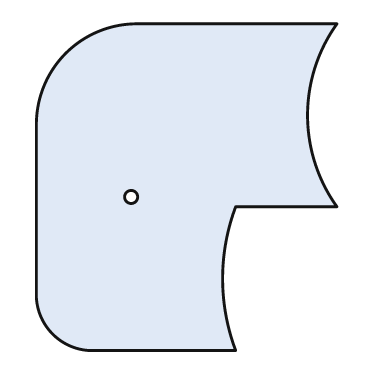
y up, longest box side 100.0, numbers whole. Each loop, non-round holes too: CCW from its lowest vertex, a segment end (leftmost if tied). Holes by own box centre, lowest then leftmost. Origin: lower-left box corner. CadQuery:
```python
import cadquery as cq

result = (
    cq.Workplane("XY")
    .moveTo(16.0, 0.0)
    .lineTo(61.0, 0.0)
    .threePointArc((57.0, 22.0), (61.0, 44.0))
    .lineTo(92.0, 44.0)
    .threePointArc((83.0, 72.0), (92.0, 100.0))
    .lineTo(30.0, 100.0)
    .threePointArc((9.0, 91.0), (0.0, 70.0))
    .lineTo(0.0, 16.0)
    .threePointArc((5.0, 5.0), (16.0, 0.0))
    .close()
    .moveTo(29.0, 47.0)
    .circle(2.0)
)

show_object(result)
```